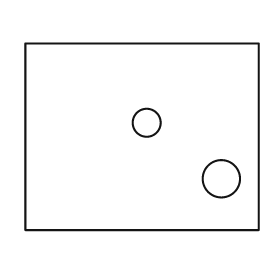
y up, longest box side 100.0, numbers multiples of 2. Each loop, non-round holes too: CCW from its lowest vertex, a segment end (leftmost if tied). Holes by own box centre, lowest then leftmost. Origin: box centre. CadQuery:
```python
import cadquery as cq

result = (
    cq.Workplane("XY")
    .moveTo(-50.0, -40.0)
    .lineTo(50.0, -40.0)
    .lineTo(50.0, 40.0)
    .lineTo(-50.0, 40.0)
    .close()
    .moveTo(34.0, -18.0)
    .circle(8.0)
    .moveTo(2.0, 6.0)
    .circle(6.0)
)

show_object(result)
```